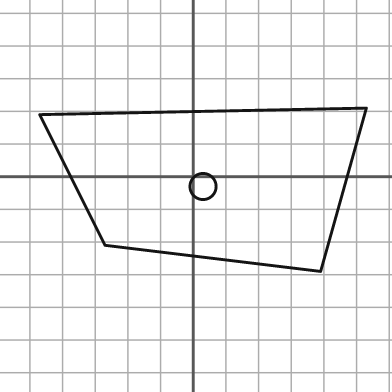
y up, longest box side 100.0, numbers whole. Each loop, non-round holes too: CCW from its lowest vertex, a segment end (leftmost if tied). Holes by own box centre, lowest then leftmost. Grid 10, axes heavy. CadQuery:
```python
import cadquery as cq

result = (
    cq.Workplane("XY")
    .moveTo(39.0, -29.0)
    .lineTo(53.0, 21.0)
    .lineTo(-47.0, 19.0)
    .lineTo(-27.0, -21.0)
    .close()
    .moveTo(3.0, -3.0)
    .circle(4.0)
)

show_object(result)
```